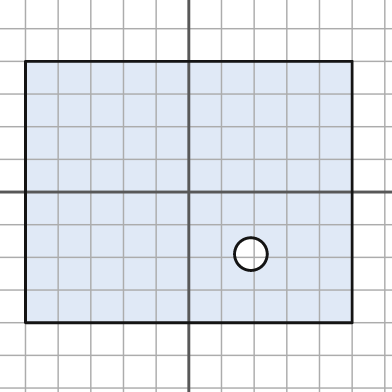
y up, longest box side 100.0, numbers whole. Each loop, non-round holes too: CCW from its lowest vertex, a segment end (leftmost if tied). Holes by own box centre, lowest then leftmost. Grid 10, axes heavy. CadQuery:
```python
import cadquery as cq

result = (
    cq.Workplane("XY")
    .moveTo(-50.0, -40.0)
    .lineTo(50.0, -40.0)
    .lineTo(50.0, 40.0)
    .lineTo(-50.0, 40.0)
    .close()
    .moveTo(19.0, -19.0)
    .circle(5.0)
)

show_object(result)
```